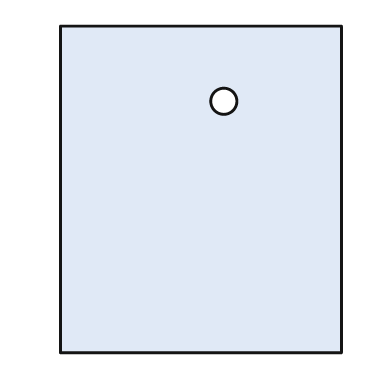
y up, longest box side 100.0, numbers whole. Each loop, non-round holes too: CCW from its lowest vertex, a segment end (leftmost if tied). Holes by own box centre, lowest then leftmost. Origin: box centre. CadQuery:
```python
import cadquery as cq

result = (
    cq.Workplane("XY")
    .moveTo(-43.0, -50.0)
    .lineTo(43.0, -50.0)
    .lineTo(43.0, 50.0)
    .lineTo(-43.0, 50.0)
    .close()
    .moveTo(7.0, 27.0)
    .circle(4.0)
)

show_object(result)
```